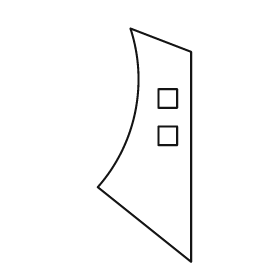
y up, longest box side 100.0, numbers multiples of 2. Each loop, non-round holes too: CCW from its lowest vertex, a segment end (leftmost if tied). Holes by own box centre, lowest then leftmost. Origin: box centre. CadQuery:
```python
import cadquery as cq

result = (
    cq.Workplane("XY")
    .moveTo(20.0, -50.0)
    .lineTo(20.0, 40.0)
    .lineTo(-6.0, 50.0)
    .threePointArc((-4.0, 14.0), (-20.0, -18.0))
    .close()
    .moveTo(6.0, 0.0)
    .lineTo(14.0, 0.0)
    .lineTo(14.0, 8.0)
    .lineTo(6.0, 8.0)
    .close()
    .moveTo(6.0, 16.0)
    .lineTo(14.0, 16.0)
    .lineTo(14.0, 24.0)
    .lineTo(6.0, 24.0)
    .close()
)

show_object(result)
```